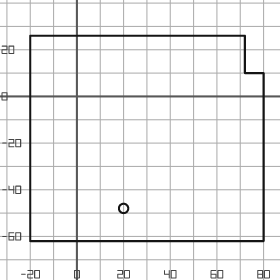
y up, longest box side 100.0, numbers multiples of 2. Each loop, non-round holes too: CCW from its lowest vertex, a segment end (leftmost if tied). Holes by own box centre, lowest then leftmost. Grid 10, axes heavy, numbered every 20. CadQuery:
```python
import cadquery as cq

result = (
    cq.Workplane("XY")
    .moveTo(-20.0, -62.0)
    .lineTo(80.0, -62.0)
    .lineTo(80.0, 10.0)
    .lineTo(72.0, 10.0)
    .lineTo(72.0, 26.0)
    .lineTo(-20.0, 26.0)
    .close()
    .moveTo(20.0, -48.0)
    .circle(2.0)
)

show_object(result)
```